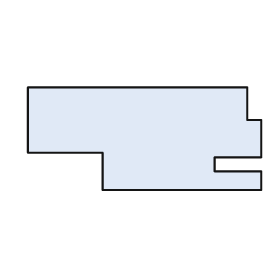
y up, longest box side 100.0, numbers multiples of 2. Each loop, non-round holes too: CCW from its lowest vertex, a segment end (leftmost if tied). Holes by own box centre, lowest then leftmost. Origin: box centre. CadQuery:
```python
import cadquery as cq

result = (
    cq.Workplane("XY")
    .moveTo(-18.0, -22.0)
    .lineTo(50.0, -22.0)
    .lineTo(50.0, -14.0)
    .lineTo(30.0, -14.0)
    .lineTo(30.0, -8.0)
    .lineTo(50.0, -8.0)
    .lineTo(50.0, 8.0)
    .lineTo(44.0, 8.0)
    .lineTo(44.0, 22.0)
    .lineTo(-50.0, 22.0)
    .lineTo(-50.0, -6.0)
    .lineTo(-18.0, -6.0)
    .close()
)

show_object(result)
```